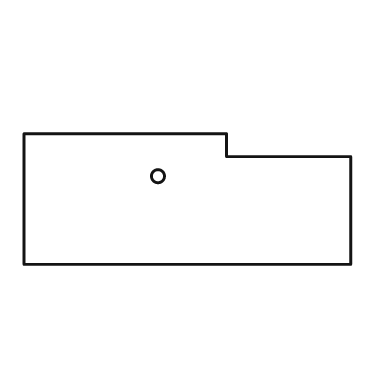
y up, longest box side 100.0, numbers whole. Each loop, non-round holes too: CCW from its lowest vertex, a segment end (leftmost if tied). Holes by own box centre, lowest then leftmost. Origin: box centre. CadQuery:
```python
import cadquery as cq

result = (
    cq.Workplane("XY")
    .moveTo(-50.0, -20.0)
    .lineTo(50.0, -20.0)
    .lineTo(50.0, 13.0)
    .lineTo(12.0, 13.0)
    .lineTo(12.0, 20.0)
    .lineTo(-50.0, 20.0)
    .close()
    .moveTo(-9.0, 7.0)
    .circle(2.0)
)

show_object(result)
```